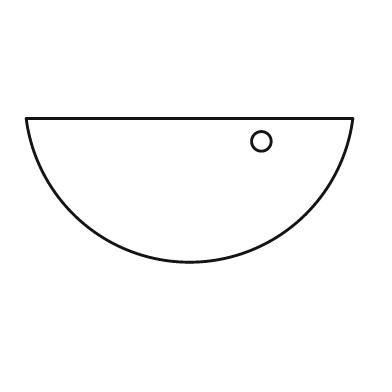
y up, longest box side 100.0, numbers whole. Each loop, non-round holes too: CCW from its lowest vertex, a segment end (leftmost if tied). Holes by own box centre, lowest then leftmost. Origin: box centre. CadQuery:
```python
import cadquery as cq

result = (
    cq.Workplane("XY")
    .moveTo(-50.0, 22.0)
    .threePointArc((0.0, -22.0), (50.0, 22.0))
    .close()
    .moveTo(22.0, 15.0)
    .circle(3.0)
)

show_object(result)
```